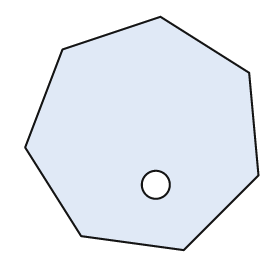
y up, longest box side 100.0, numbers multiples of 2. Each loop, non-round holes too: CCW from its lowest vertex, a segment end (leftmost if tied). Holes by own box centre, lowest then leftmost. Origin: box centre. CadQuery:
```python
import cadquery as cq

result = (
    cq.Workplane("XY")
    .moveTo(18.0, -50.0)
    .lineTo(50.0, -18.0)
    .lineTo(46.0, 26.0)
    .lineTo(8.0, 50.0)
    .lineTo(-34.0, 36.0)
    .lineTo(-50.0, -6.0)
    .lineTo(-26.0, -44.0)
    .close()
    .moveTo(6.0, -22.0)
    .circle(6.0)
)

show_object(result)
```